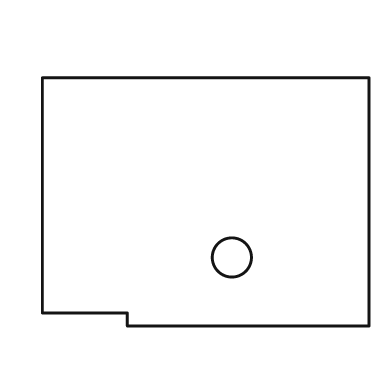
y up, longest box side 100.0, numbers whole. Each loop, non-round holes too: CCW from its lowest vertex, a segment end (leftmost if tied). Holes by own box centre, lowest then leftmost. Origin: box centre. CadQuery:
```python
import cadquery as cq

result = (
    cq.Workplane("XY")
    .moveTo(-24.0, -38.0)
    .lineTo(50.0, -38.0)
    .lineTo(50.0, 38.0)
    .lineTo(-50.0, 38.0)
    .lineTo(-50.0, -34.0)
    .lineTo(-24.0, -34.0)
    .close()
    .moveTo(8.0, -17.0)
    .circle(6.0)
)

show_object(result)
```